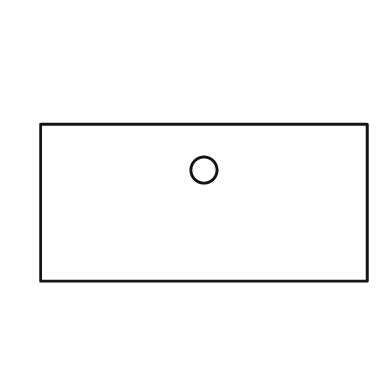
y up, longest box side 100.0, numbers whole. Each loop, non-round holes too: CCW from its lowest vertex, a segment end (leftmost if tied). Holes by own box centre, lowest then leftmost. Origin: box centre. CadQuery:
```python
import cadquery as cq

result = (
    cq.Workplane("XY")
    .moveTo(-50.0, -24.0)
    .lineTo(50.0, -24.0)
    .lineTo(50.0, 24.0)
    .lineTo(-50.0, 24.0)
    .close()
    .moveTo(0.0, 10.0)
    .circle(4.0)
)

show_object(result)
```